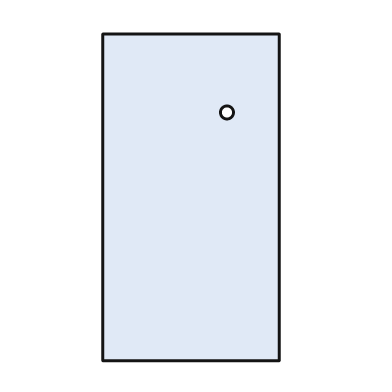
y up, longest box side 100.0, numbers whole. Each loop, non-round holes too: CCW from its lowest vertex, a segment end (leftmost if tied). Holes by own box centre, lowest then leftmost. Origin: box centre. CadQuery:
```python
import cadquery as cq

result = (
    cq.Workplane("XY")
    .moveTo(-27.0, -50.0)
    .lineTo(27.0, -50.0)
    .lineTo(27.0, 50.0)
    .lineTo(-27.0, 50.0)
    .close()
    .moveTo(11.0, 26.0)
    .circle(2.0)
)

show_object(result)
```